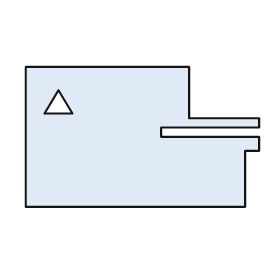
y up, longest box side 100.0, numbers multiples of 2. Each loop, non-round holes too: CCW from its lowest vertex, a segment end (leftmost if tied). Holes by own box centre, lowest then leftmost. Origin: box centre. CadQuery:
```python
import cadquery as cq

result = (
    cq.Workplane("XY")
    .moveTo(-50.0, -30.0)
    .lineTo(44.0, -30.0)
    .lineTo(44.0, -6.0)
    .lineTo(50.0, -6.0)
    .lineTo(50.0, 0.0)
    .lineTo(8.0, 0.0)
    .lineTo(8.0, 4.0)
    .lineTo(50.0, 4.0)
    .lineTo(50.0, 8.0)
    .lineTo(20.0, 8.0)
    .lineTo(20.0, 30.0)
    .lineTo(-50.0, 30.0)
    .close()
    .moveTo(-42.0, 10.0)
    .lineTo(-30.0, 10.0)
    .lineTo(-36.0, 20.0)
    .close()
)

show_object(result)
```